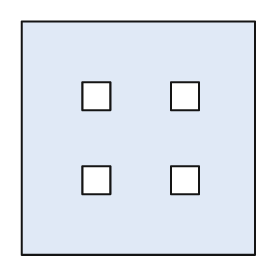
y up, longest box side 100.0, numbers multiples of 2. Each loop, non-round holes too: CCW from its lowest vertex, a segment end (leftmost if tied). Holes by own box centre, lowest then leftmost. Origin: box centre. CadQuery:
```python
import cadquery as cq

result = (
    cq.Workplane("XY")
    .moveTo(-50.0, -50.0)
    .lineTo(50.0, -50.0)
    .lineTo(50.0, 50.0)
    .lineTo(-50.0, 50.0)
    .close()
    .moveTo(-24.0, -24.0)
    .lineTo(-12.0, -24.0)
    .lineTo(-12.0, -12.0)
    .lineTo(-24.0, -12.0)
    .close()
    .moveTo(14.0, -24.0)
    .lineTo(26.0, -24.0)
    .lineTo(26.0, -12.0)
    .lineTo(14.0, -12.0)
    .close()
    .moveTo(-24.0, 12.0)
    .lineTo(-12.0, 12.0)
    .lineTo(-12.0, 24.0)
    .lineTo(-24.0, 24.0)
    .close()
    .moveTo(14.0, 12.0)
    .lineTo(26.0, 12.0)
    .lineTo(26.0, 24.0)
    .lineTo(14.0, 24.0)
    .close()
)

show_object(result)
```